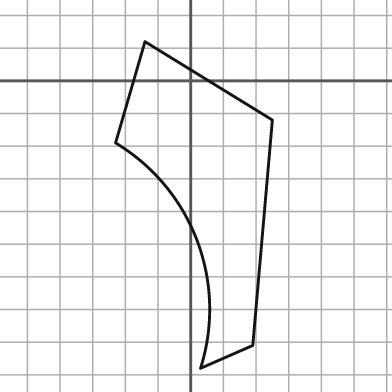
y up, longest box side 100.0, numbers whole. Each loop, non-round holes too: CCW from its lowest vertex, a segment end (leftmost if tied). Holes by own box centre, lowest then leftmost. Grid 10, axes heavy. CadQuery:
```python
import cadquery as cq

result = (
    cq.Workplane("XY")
    .moveTo(3.0, -88.0)
    .lineTo(19.0, -81.0)
    .lineTo(25.0, -12.0)
    .lineTo(-14.0, 12.0)
    .lineTo(-23.0, -19.0)
    .threePointArc((2.0, -49.0), (3.0, -88.0))
    .close()
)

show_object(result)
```